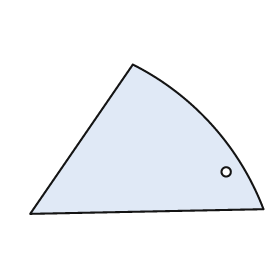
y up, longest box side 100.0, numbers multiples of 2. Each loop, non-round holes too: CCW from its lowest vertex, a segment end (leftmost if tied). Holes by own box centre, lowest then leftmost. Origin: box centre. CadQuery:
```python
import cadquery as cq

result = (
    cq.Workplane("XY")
    .moveTo(-50.0, -32.0)
    .lineTo(50.0, -30.0)
    .threePointArc((28.0, 6.0), (-6.0, 32.0))
    .close()
    .moveTo(34.0, -14.0)
    .circle(2.0)
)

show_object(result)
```